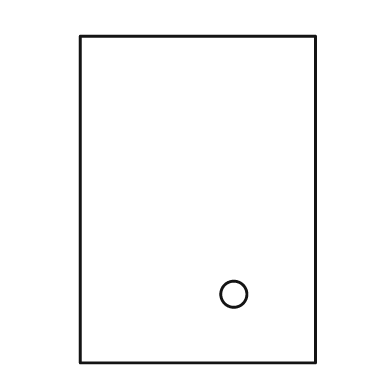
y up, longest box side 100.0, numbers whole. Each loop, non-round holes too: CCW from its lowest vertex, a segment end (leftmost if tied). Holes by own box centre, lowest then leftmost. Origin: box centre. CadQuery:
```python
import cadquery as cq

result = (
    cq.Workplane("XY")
    .moveTo(-36.0, -50.0)
    .lineTo(36.0, -50.0)
    .lineTo(36.0, 50.0)
    .lineTo(-36.0, 50.0)
    .close()
    .moveTo(11.0, -29.0)
    .circle(4.0)
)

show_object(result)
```